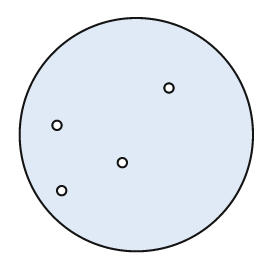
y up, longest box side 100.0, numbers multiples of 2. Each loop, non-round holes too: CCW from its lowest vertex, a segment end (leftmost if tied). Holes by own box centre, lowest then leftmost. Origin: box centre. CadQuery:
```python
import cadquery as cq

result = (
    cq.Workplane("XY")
    .moveTo(0.0, 0.0)
    .circle(50.0)
    .moveTo(-32.0, -24.0)
    .circle(2.0)
    .moveTo(-6.0, -12.0)
    .circle(2.0)
    .moveTo(-34.0, 4.0)
    .circle(2.0)
    .moveTo(14.0, 20.0)
    .circle(2.0)
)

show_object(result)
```